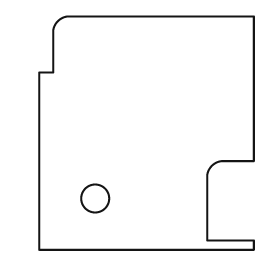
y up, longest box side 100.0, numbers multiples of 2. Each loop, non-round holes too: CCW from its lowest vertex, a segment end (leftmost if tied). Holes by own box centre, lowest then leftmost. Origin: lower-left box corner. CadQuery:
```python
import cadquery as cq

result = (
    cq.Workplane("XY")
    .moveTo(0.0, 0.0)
    .lineTo(92.0, 0.0)
    .lineTo(92.0, 4.0)
    .lineTo(72.0, 4.0)
    .lineTo(72.0, 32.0)
    .threePointArc((74.0, 36.0), (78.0, 38.0))
    .lineTo(92.0, 38.0)
    .lineTo(92.0, 100.0)
    .lineTo(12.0, 100.0)
    .threePointArc((8.0, 98.0), (6.0, 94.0))
    .lineTo(6.0, 76.0)
    .lineTo(0.0, 76.0)
    .close()
    .moveTo(24.0, 22.0)
    .circle(6.0)
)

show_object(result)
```